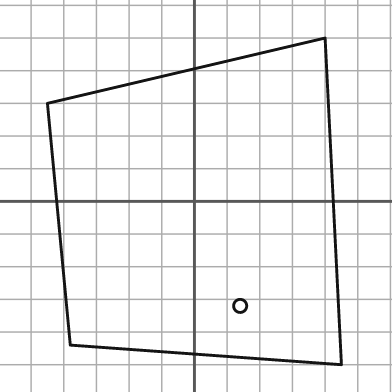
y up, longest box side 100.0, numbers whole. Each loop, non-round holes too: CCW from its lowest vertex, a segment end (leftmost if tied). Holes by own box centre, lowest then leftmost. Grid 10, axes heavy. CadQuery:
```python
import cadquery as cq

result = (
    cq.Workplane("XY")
    .moveTo(45.0, -50.0)
    .lineTo(40.0, 50.0)
    .lineTo(-45.0, 30.0)
    .lineTo(-38.0, -44.0)
    .close()
    .moveTo(14.0, -32.0)
    .circle(2.0)
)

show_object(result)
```